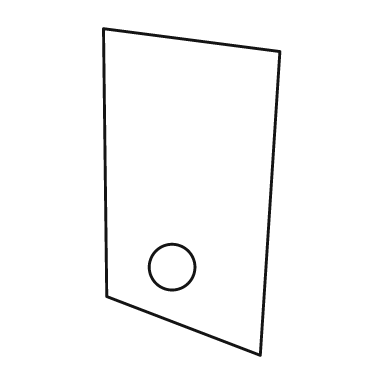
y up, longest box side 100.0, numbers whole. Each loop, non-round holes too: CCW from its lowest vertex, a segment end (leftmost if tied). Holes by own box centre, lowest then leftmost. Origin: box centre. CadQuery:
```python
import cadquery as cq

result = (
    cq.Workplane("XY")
    .moveTo(21.0, -50.0)
    .lineTo(27.0, 43.0)
    .lineTo(-27.0, 50.0)
    .lineTo(-26.0, -32.0)
    .close()
    .moveTo(-6.0, -23.0)
    .circle(7.0)
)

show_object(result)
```